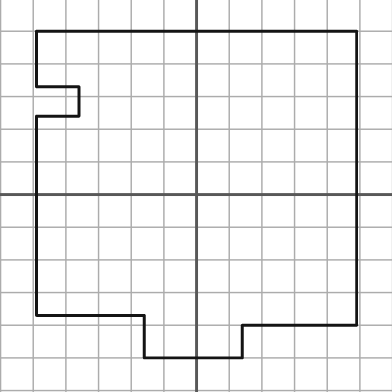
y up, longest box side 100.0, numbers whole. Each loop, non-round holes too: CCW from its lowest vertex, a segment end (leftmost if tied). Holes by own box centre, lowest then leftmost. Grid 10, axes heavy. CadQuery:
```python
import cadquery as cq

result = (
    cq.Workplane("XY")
    .moveTo(-16.0, -50.0)
    .lineTo(14.0, -50.0)
    .lineTo(14.0, -40.0)
    .lineTo(49.0, -40.0)
    .lineTo(49.0, 50.0)
    .lineTo(-49.0, 50.0)
    .lineTo(-49.0, 33.0)
    .lineTo(-36.0, 33.0)
    .lineTo(-36.0, 24.0)
    .lineTo(-49.0, 24.0)
    .lineTo(-49.0, -37.0)
    .lineTo(-16.0, -37.0)
    .close()
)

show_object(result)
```